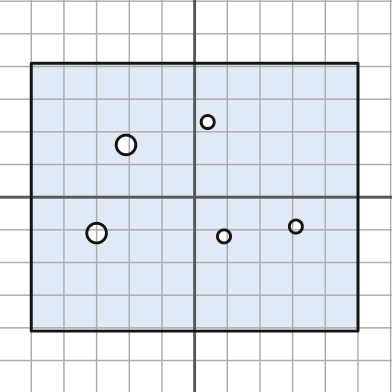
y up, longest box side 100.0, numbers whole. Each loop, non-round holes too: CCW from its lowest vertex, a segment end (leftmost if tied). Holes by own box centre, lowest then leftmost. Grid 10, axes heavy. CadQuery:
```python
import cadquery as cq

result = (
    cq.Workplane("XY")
    .moveTo(-50.0, -41.0)
    .lineTo(50.0, -41.0)
    .lineTo(50.0, 41.0)
    .lineTo(-50.0, 41.0)
    .close()
    .moveTo(9.0, -12.0)
    .circle(2.0)
    .moveTo(-30.0, -11.0)
    .circle(3.0)
    .moveTo(31.0, -9.0)
    .circle(2.0)
    .moveTo(-21.0, 16.0)
    .circle(3.0)
    .moveTo(4.0, 23.0)
    .circle(2.0)
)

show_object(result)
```